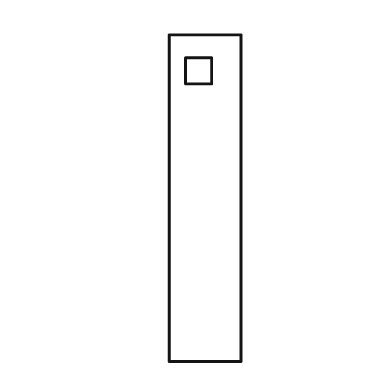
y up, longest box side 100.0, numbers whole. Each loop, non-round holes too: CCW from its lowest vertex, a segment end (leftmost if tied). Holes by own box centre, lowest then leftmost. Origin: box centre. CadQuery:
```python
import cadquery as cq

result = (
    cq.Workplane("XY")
    .moveTo(-11.0, -50.0)
    .lineTo(11.0, -50.0)
    .lineTo(11.0, 50.0)
    .lineTo(-11.0, 50.0)
    .close()
    .moveTo(-6.0, 35.0)
    .lineTo(2.0, 35.0)
    .lineTo(2.0, 43.0)
    .lineTo(-6.0, 43.0)
    .close()
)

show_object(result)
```